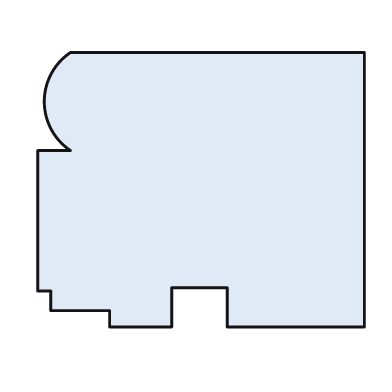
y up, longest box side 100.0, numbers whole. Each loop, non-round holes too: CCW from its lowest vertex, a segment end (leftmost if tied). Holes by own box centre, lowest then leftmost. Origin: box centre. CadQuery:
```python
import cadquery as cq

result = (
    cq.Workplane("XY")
    .moveTo(-28.0, -42.0)
    .lineTo(-9.0, -42.0)
    .lineTo(-9.0, -30.0)
    .lineTo(8.0, -30.0)
    .lineTo(8.0, -42.0)
    .lineTo(50.0, -42.0)
    .lineTo(50.0, 42.0)
    .lineTo(-40.0, 42.0)
    .threePointArc((-48.0, 27.0), (-40.0, 12.0))
    .lineTo(-50.0, 12.0)
    .lineTo(-50.0, -31.0)
    .lineTo(-46.0, -31.0)
    .lineTo(-46.0, -37.0)
    .lineTo(-28.0, -37.0)
    .close()
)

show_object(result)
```